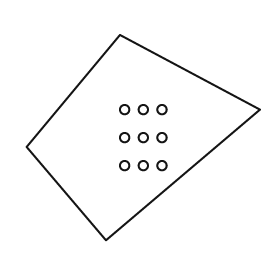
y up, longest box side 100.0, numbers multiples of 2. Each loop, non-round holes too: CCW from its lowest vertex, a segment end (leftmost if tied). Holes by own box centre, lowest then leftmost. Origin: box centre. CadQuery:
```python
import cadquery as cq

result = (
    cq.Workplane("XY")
    .moveTo(-16.0, -44.0)
    .lineTo(50.0, 12.0)
    .lineTo(-10.0, 44.0)
    .lineTo(-50.0, -4.0)
    .close()
    .moveTo(-8.0, -12.0)
    .circle(2.0)
    .moveTo(0.0, -12.0)
    .circle(2.0)
    .moveTo(8.0, -12.0)
    .circle(2.0)
    .moveTo(-8.0, 0.0)
    .circle(2.0)
    .moveTo(0.0, 0.0)
    .circle(2.0)
    .moveTo(8.0, 0.0)
    .circle(2.0)
    .moveTo(-8.0, 12.0)
    .circle(2.0)
    .moveTo(0.0, 12.0)
    .circle(2.0)
    .moveTo(8.0, 12.0)
    .circle(2.0)
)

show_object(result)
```